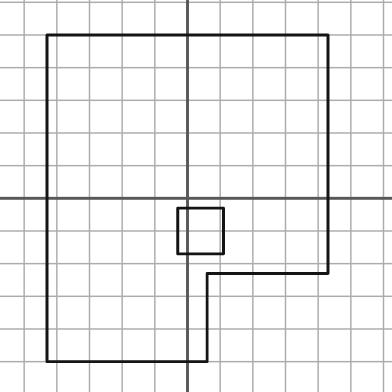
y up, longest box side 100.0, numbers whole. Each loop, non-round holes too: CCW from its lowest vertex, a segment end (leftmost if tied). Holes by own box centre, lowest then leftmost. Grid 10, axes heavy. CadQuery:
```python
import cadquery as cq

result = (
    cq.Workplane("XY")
    .moveTo(-43.0, -50.0)
    .lineTo(6.0, -50.0)
    .lineTo(6.0, -23.0)
    .lineTo(43.0, -23.0)
    .lineTo(43.0, 50.0)
    .lineTo(-43.0, 50.0)
    .close()
    .moveTo(-3.0, -17.0)
    .lineTo(11.0, -17.0)
    .lineTo(11.0, -3.0)
    .lineTo(-3.0, -3.0)
    .close()
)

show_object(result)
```